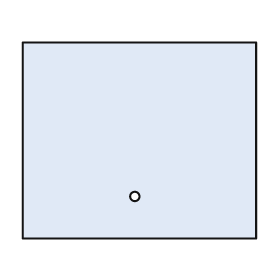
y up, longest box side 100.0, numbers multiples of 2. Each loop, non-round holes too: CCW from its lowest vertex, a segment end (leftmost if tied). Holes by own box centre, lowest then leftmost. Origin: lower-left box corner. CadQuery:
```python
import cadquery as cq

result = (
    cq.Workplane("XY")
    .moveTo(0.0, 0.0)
    .lineTo(100.0, 0.0)
    .lineTo(100.0, 84.0)
    .lineTo(0.0, 84.0)
    .close()
    .moveTo(48.0, 18.0)
    .circle(2.0)
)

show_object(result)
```